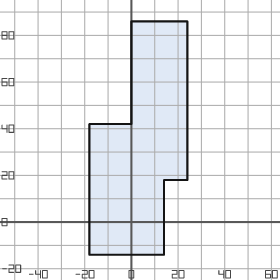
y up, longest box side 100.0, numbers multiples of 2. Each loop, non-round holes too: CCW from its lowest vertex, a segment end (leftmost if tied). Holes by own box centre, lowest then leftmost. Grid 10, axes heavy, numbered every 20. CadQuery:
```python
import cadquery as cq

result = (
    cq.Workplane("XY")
    .moveTo(-18.0, -14.0)
    .lineTo(14.0, -14.0)
    .lineTo(14.0, 18.0)
    .lineTo(24.0, 18.0)
    .lineTo(24.0, 86.0)
    .lineTo(0.0, 86.0)
    .lineTo(0.0, 42.0)
    .lineTo(-18.0, 42.0)
    .close()
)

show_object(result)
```